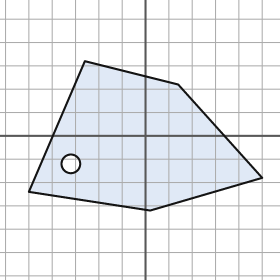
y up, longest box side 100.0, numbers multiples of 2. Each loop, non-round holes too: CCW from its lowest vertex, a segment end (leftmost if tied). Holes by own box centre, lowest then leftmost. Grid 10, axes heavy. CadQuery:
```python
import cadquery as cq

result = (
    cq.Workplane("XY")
    .moveTo(2.0, -32.0)
    .lineTo(50.0, -18.0)
    .lineTo(14.0, 22.0)
    .lineTo(-26.0, 32.0)
    .lineTo(-50.0, -24.0)
    .close()
    .moveTo(-32.0, -12.0)
    .circle(4.0)
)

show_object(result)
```